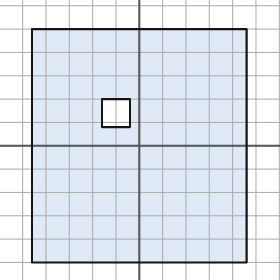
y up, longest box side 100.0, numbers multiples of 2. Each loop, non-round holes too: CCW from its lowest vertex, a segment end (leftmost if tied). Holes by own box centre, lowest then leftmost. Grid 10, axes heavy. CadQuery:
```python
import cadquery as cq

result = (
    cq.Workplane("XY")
    .moveTo(-46.0, -50.0)
    .lineTo(46.0, -50.0)
    .lineTo(46.0, 50.0)
    .lineTo(-46.0, 50.0)
    .close()
    .moveTo(-16.0, 8.0)
    .lineTo(-4.0, 8.0)
    .lineTo(-4.0, 20.0)
    .lineTo(-16.0, 20.0)
    .close()
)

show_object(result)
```